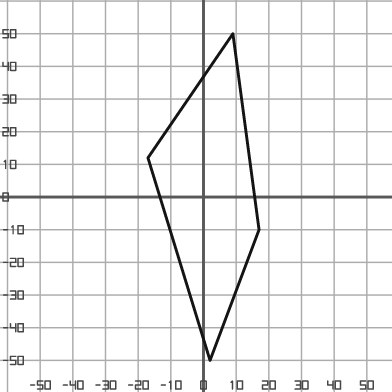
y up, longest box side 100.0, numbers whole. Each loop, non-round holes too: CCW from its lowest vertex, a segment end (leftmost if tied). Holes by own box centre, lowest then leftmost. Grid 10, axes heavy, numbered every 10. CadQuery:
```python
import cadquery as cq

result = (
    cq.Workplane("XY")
    .moveTo(2.0, -50.0)
    .lineTo(17.0, -10.0)
    .lineTo(9.0, 50.0)
    .lineTo(-17.0, 12.0)
    .close()
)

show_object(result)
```